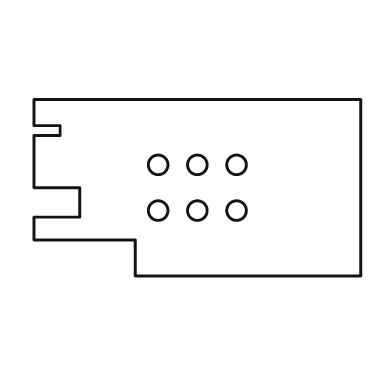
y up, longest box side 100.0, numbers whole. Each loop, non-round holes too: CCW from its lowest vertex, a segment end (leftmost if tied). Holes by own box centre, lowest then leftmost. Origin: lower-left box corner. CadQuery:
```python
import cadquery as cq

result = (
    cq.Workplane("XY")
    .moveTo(31.0, 0.0)
    .lineTo(100.0, 0.0)
    .lineTo(100.0, 54.0)
    .lineTo(0.0, 54.0)
    .lineTo(0.0, 46.0)
    .lineTo(8.0, 46.0)
    .lineTo(8.0, 43.0)
    .lineTo(0.0, 43.0)
    .lineTo(0.0, 27.0)
    .lineTo(14.0, 27.0)
    .lineTo(14.0, 18.0)
    .lineTo(0.0, 18.0)
    .lineTo(0.0, 11.0)
    .lineTo(31.0, 11.0)
    .close()
    .moveTo(38.0, 20.0)
    .circle(3.0)
    .moveTo(50.0, 20.0)
    .circle(3.0)
    .moveTo(62.0, 20.0)
    .circle(3.0)
    .moveTo(38.0, 34.0)
    .circle(3.0)
    .moveTo(50.0, 34.0)
    .circle(3.0)
    .moveTo(62.0, 34.0)
    .circle(3.0)
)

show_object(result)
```